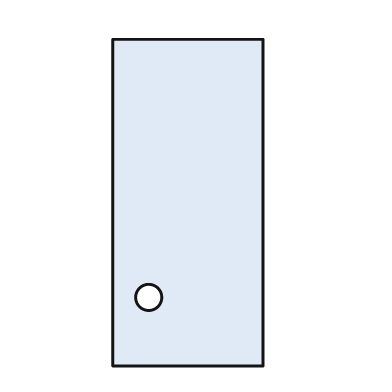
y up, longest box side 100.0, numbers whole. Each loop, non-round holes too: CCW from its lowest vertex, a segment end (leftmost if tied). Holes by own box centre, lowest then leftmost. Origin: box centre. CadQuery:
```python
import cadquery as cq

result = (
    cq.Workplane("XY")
    .moveTo(-23.0, -50.0)
    .lineTo(23.0, -50.0)
    .lineTo(23.0, 50.0)
    .lineTo(-23.0, 50.0)
    .close()
    .moveTo(-12.0, -29.0)
    .circle(4.0)
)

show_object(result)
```